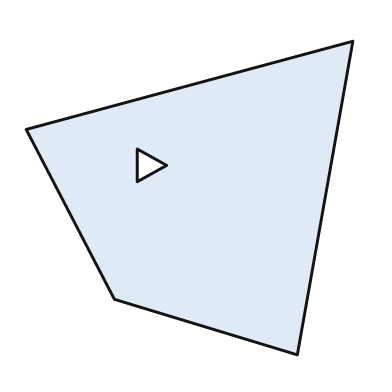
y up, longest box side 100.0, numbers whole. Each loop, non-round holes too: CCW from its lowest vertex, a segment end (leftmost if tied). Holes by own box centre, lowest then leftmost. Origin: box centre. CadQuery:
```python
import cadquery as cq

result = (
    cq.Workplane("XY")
    .moveTo(33.0, -48.0)
    .lineTo(50.0, 48.0)
    .lineTo(-50.0, 21.0)
    .lineTo(-23.0, -31.0)
    .close()
    .moveTo(-16.0, 5.0)
    .lineTo(-7.0, 10.0)
    .lineTo(-16.0, 15.0)
    .close()
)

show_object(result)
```